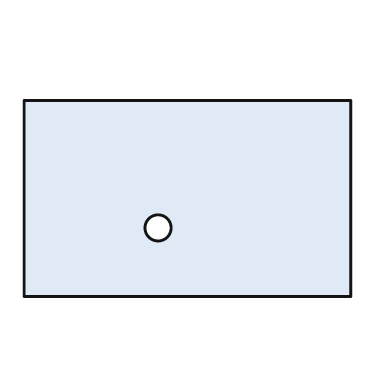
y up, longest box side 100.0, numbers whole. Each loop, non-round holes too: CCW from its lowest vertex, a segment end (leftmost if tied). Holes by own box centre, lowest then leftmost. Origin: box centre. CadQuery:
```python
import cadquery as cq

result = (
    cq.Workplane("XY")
    .moveTo(-50.0, -30.0)
    .lineTo(50.0, -30.0)
    .lineTo(50.0, 30.0)
    .lineTo(-50.0, 30.0)
    .close()
    .moveTo(-9.0, -9.0)
    .circle(4.0)
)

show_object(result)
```